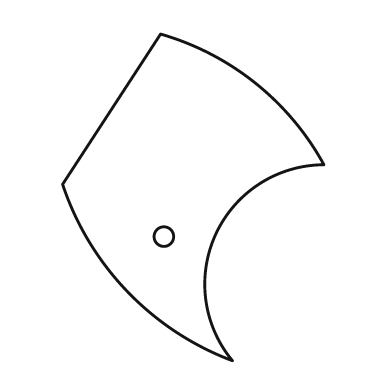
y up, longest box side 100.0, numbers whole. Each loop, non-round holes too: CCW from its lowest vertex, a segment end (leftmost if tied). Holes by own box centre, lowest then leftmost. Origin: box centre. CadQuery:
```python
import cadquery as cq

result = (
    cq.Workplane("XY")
    .moveTo(12.0, -50.0)
    .threePointArc((7.0, -11.0), (40.0, 10.0))
    .threePointArc((19.0, 35.0), (-10.0, 50.0))
    .lineTo(-40.0, 4.0)
    .threePointArc((-20.0, -29.0), (12.0, -50.0))
    .close()
    .moveTo(-9.0, -12.0)
    .circle(3.0)
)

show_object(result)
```